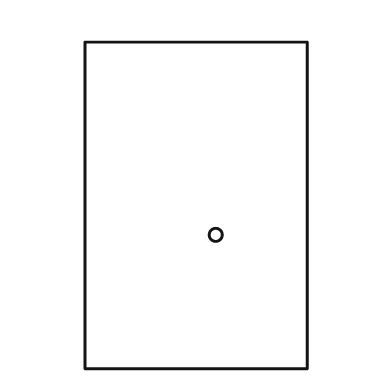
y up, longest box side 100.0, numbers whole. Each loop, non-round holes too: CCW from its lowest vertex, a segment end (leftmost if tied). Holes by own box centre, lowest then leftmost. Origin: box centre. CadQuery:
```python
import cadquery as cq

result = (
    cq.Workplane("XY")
    .moveTo(-34.0, -50.0)
    .lineTo(34.0, -50.0)
    .lineTo(34.0, 50.0)
    .lineTo(-34.0, 50.0)
    .close()
    .moveTo(6.0, -9.0)
    .circle(2.0)
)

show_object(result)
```